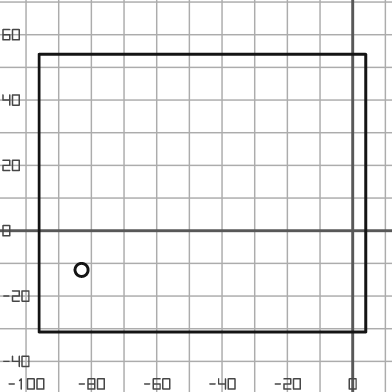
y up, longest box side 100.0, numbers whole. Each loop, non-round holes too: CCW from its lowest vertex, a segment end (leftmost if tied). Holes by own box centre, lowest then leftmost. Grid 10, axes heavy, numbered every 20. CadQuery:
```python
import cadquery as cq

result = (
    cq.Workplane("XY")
    .moveTo(-96.0, -31.0)
    .lineTo(4.0, -31.0)
    .lineTo(4.0, 54.0)
    .lineTo(-96.0, 54.0)
    .close()
    .moveTo(-83.0, -12.0)
    .circle(2.0)
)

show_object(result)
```